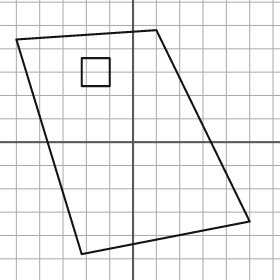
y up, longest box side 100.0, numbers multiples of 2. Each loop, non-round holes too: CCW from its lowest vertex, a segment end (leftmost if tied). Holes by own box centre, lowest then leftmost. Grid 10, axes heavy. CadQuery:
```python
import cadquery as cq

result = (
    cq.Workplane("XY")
    .moveTo(-22.0, -48.0)
    .lineTo(50.0, -34.0)
    .lineTo(10.0, 48.0)
    .lineTo(-50.0, 44.0)
    .close()
    .moveTo(-22.0, 24.0)
    .lineTo(-10.0, 24.0)
    .lineTo(-10.0, 36.0)
    .lineTo(-22.0, 36.0)
    .close()
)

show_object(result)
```